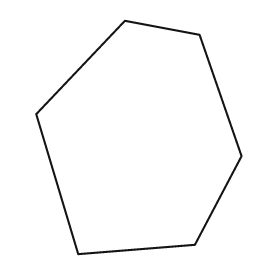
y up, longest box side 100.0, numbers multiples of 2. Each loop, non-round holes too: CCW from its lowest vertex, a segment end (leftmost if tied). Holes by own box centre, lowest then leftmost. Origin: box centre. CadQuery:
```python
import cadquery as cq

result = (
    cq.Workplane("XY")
    .moveTo(-26.0, -50.0)
    .lineTo(24.0, -46.0)
    .lineTo(44.0, -8.0)
    .lineTo(26.0, 44.0)
    .lineTo(-6.0, 50.0)
    .lineTo(-44.0, 10.0)
    .close()
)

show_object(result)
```